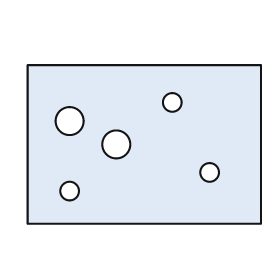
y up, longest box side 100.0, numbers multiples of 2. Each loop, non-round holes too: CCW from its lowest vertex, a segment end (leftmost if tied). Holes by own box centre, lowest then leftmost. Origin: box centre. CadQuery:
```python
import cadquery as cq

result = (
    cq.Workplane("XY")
    .moveTo(-50.0, -34.0)
    .lineTo(50.0, -34.0)
    .lineTo(50.0, 34.0)
    .lineTo(-50.0, 34.0)
    .close()
    .moveTo(-32.0, -20.0)
    .circle(4.0)
    .moveTo(28.0, -12.0)
    .circle(4.0)
    .moveTo(-12.0, 0.0)
    .circle(6.0)
    .moveTo(-32.0, 10.0)
    .circle(6.0)
    .moveTo(12.0, 18.0)
    .circle(4.0)
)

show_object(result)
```